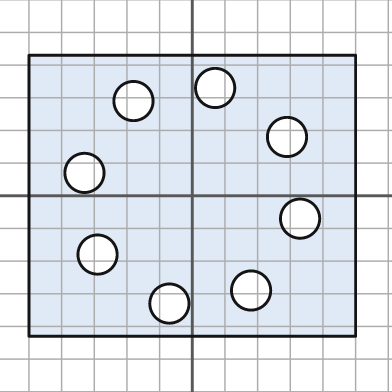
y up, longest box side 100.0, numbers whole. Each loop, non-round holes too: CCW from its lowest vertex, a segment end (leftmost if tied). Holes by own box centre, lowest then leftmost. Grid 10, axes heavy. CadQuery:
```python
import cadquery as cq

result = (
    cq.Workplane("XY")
    .moveTo(-50.0, -43.0)
    .lineTo(50.0, -43.0)
    .lineTo(50.0, 43.0)
    .lineTo(-50.0, 43.0)
    .close()
    .moveTo(-7.0, -33.0)
    .circle(6.0)
    .moveTo(18.0, -29.0)
    .circle(6.0)
    .moveTo(-29.0, -18.0)
    .circle(6.0)
    .moveTo(33.0, -7.0)
    .circle(6.0)
    .moveTo(-33.0, 7.0)
    .circle(6.0)
    .moveTo(29.0, 18.0)
    .circle(6.0)
    .moveTo(-18.0, 29.0)
    .circle(6.0)
    .moveTo(7.0, 33.0)
    .circle(6.0)
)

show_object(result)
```